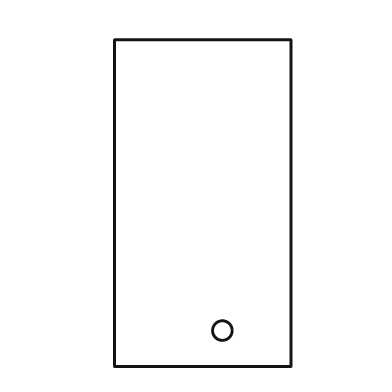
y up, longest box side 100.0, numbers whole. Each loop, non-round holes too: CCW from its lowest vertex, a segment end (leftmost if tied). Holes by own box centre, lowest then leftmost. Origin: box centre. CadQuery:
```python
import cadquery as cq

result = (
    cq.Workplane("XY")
    .moveTo(-27.0, -50.0)
    .lineTo(27.0, -50.0)
    .lineTo(27.0, 50.0)
    .lineTo(-27.0, 50.0)
    .close()
    .moveTo(6.0, -39.0)
    .circle(3.0)
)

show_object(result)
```